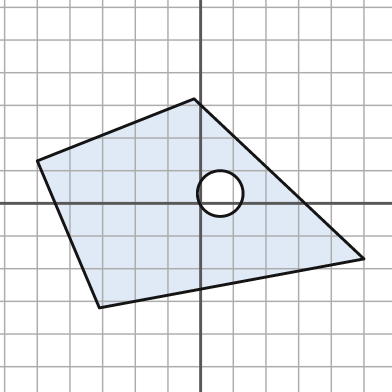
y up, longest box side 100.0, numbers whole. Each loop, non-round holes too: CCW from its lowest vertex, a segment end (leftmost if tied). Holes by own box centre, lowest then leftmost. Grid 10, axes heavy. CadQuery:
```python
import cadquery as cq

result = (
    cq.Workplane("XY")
    .moveTo(-31.0, -32.0)
    .lineTo(50.0, -17.0)
    .lineTo(-2.0, 32.0)
    .lineTo(-50.0, 13.0)
    .close()
    .moveTo(6.0, 3.0)
    .circle(7.0)
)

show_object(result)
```